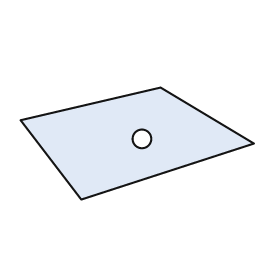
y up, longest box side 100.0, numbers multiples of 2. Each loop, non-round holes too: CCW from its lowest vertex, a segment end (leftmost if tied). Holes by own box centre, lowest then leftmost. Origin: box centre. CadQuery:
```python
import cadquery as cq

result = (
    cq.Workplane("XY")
    .moveTo(-24.0, -24.0)
    .lineTo(50.0, 0.0)
    .lineTo(10.0, 24.0)
    .lineTo(-50.0, 10.0)
    .close()
    .moveTo(2.0, 2.0)
    .circle(4.0)
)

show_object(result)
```